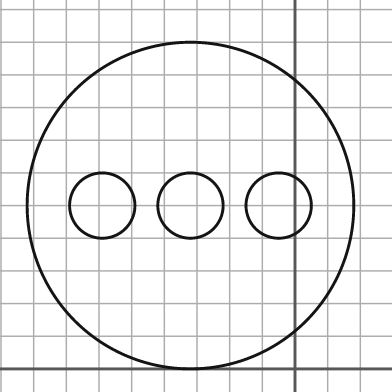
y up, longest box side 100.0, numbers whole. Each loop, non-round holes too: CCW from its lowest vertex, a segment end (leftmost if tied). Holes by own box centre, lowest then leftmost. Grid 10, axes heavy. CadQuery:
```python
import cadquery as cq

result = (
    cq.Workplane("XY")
    .moveTo(-32.0, 50.0)
    .circle(50.0)
    .moveTo(-59.0, 50.0)
    .circle(10.0)
    .moveTo(-32.0, 50.0)
    .circle(10.0)
    .moveTo(-5.0, 50.0)
    .circle(10.0)
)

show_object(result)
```